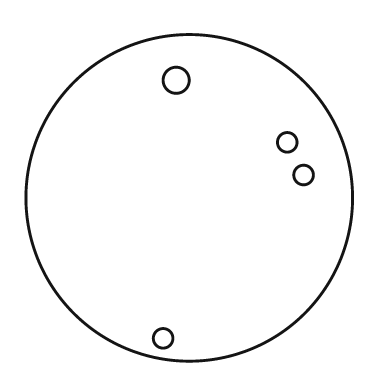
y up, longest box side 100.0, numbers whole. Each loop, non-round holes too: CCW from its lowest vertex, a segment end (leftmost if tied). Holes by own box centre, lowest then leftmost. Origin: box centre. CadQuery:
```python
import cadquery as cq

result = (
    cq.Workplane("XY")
    .moveTo(0.0, 0.0)
    .circle(50.0)
    .moveTo(-8.0, -43.0)
    .circle(3.0)
    .moveTo(35.0, 7.0)
    .circle(3.0)
    .moveTo(30.0, 17.0)
    .circle(3.0)
    .moveTo(-4.0, 36.0)
    .circle(4.0)
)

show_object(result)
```